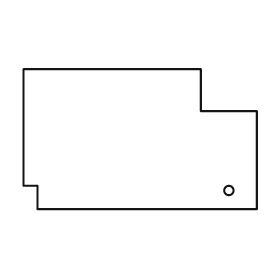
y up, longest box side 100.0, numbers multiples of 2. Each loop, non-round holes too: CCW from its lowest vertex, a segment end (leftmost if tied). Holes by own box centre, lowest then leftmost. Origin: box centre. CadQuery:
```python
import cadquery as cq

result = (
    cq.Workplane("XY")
    .moveTo(-44.0, -30.0)
    .lineTo(50.0, -30.0)
    .lineTo(50.0, 12.0)
    .lineTo(26.0, 12.0)
    .lineTo(26.0, 30.0)
    .lineTo(-50.0, 30.0)
    .lineTo(-50.0, -20.0)
    .lineTo(-44.0, -20.0)
    .close()
    .moveTo(38.0, -22.0)
    .circle(2.0)
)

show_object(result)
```